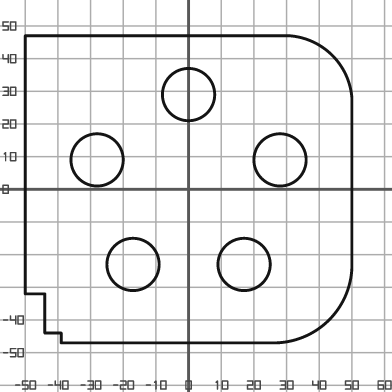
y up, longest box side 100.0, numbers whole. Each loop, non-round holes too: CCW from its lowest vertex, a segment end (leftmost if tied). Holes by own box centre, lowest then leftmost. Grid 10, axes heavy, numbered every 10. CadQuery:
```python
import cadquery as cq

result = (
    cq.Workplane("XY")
    .moveTo(-39.0, -47.0)
    .lineTo(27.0, -47.0)
    .threePointArc((43.0, -40.0), (50.0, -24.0))
    .lineTo(50.0, 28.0)
    .threePointArc((44.0, 41.0), (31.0, 47.0))
    .lineTo(-50.0, 47.0)
    .lineTo(-50.0, -32.0)
    .lineTo(-44.0, -32.0)
    .lineTo(-44.0, -44.0)
    .lineTo(-39.0, -44.0)
    .close()
    .moveTo(-17.0, -23.0)
    .circle(8.0)
    .moveTo(17.0, -23.0)
    .circle(8.0)
    .moveTo(-28.0, 9.0)
    .circle(8.0)
    .moveTo(28.0, 9.0)
    .circle(8.0)
    .moveTo(0.0, 29.0)
    .circle(8.0)
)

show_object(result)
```